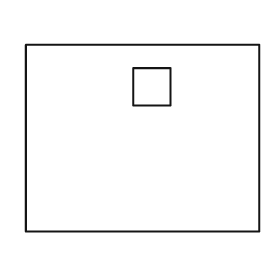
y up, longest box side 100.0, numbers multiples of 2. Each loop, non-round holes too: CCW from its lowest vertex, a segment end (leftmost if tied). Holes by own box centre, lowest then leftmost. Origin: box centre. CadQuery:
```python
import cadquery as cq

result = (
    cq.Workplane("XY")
    .moveTo(-50.0, -40.0)
    .lineTo(50.0, -40.0)
    .lineTo(50.0, 40.0)
    .lineTo(-50.0, 40.0)
    .close()
    .moveTo(-4.0, 14.0)
    .lineTo(12.0, 14.0)
    .lineTo(12.0, 30.0)
    .lineTo(-4.0, 30.0)
    .close()
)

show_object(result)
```